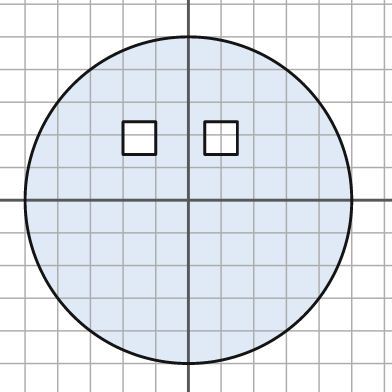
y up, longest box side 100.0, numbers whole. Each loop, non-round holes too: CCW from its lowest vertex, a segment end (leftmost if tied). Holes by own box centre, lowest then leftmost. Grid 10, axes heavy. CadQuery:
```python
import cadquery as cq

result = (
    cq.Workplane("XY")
    .moveTo(0.0, 0.0)
    .circle(50.0)
    .moveTo(-20.0, 14.0)
    .lineTo(-10.0, 14.0)
    .lineTo(-10.0, 24.0)
    .lineTo(-20.0, 24.0)
    .close()
    .moveTo(5.0, 14.0)
    .lineTo(15.0, 14.0)
    .lineTo(15.0, 24.0)
    .lineTo(5.0, 24.0)
    .close()
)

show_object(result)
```